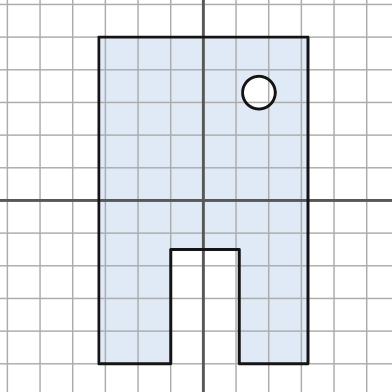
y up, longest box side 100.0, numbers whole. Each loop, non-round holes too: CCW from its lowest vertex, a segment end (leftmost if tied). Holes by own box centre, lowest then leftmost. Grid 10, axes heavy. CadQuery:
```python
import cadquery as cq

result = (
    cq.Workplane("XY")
    .moveTo(-32.0, -50.0)
    .lineTo(-10.0, -50.0)
    .lineTo(-10.0, -15.0)
    .lineTo(11.0, -15.0)
    .lineTo(11.0, -50.0)
    .lineTo(32.0, -50.0)
    .lineTo(32.0, 50.0)
    .lineTo(-32.0, 50.0)
    .close()
    .moveTo(17.0, 33.0)
    .circle(5.0)
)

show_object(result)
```